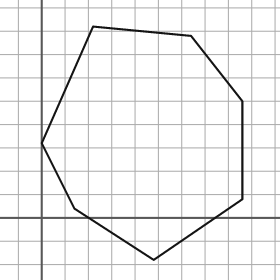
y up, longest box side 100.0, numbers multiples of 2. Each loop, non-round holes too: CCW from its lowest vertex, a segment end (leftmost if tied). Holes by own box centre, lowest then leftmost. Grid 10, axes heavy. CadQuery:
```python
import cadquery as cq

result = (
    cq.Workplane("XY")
    .moveTo(48.0, -18.0)
    .lineTo(86.0, 8.0)
    .lineTo(86.0, 50.0)
    .lineTo(64.0, 78.0)
    .lineTo(22.0, 82.0)
    .lineTo(0.0, 32.0)
    .lineTo(14.0, 4.0)
    .close()
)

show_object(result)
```